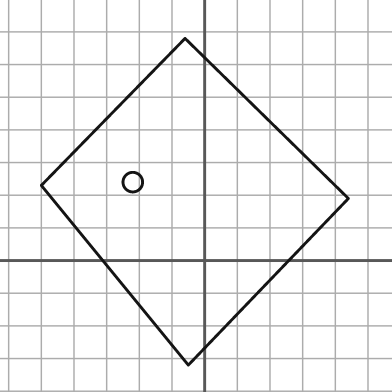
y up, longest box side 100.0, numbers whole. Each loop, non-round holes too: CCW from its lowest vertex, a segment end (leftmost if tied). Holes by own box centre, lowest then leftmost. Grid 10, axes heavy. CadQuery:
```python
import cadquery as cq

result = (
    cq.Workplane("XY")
    .moveTo(-5.0, -32.0)
    .lineTo(44.0, 19.0)
    .lineTo(-6.0, 68.0)
    .lineTo(-50.0, 23.0)
    .close()
    .moveTo(-22.0, 24.0)
    .circle(3.0)
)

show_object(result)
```